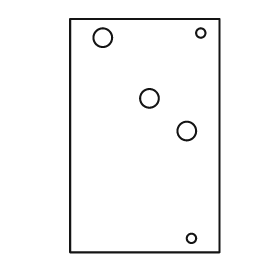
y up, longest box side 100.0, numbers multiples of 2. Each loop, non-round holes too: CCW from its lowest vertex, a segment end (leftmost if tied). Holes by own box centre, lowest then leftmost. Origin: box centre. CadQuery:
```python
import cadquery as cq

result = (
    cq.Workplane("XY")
    .moveTo(-32.0, -50.0)
    .lineTo(32.0, -50.0)
    .lineTo(32.0, 50.0)
    .lineTo(-32.0, 50.0)
    .close()
    .moveTo(20.0, -44.0)
    .circle(2.0)
    .moveTo(18.0, 2.0)
    .circle(4.0)
    .moveTo(2.0, 16.0)
    .circle(4.0)
    .moveTo(-18.0, 42.0)
    .circle(4.0)
    .moveTo(24.0, 44.0)
    .circle(2.0)
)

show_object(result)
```